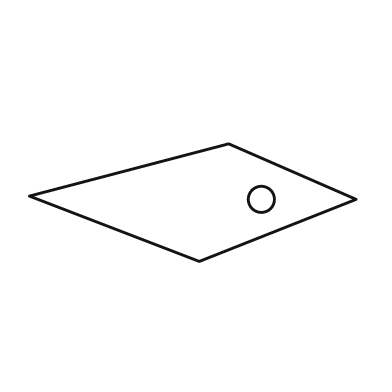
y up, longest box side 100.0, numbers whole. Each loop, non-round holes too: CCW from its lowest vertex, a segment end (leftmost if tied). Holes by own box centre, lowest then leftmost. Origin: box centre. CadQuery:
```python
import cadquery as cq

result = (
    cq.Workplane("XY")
    .moveTo(2.0, -18.0)
    .lineTo(50.0, 1.0)
    .lineTo(11.0, 18.0)
    .lineTo(-50.0, 2.0)
    .close()
    .moveTo(21.0, 1.0)
    .circle(4.0)
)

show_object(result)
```